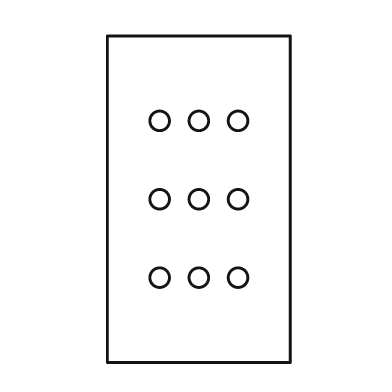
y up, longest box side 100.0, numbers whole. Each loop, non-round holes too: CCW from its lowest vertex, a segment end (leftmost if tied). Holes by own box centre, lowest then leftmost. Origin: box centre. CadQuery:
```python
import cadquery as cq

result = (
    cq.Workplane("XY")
    .moveTo(-28.0, -50.0)
    .lineTo(28.0, -50.0)
    .lineTo(28.0, 50.0)
    .lineTo(-28.0, 50.0)
    .close()
    .moveTo(-12.0, -24.0)
    .circle(3.0)
    .moveTo(0.0, -24.0)
    .circle(3.0)
    .moveTo(12.0, -24.0)
    .circle(3.0)
    .moveTo(-12.0, 0.0)
    .circle(3.0)
    .moveTo(0.0, 0.0)
    .circle(3.0)
    .moveTo(12.0, 0.0)
    .circle(3.0)
    .moveTo(-12.0, 24.0)
    .circle(3.0)
    .moveTo(0.0, 24.0)
    .circle(3.0)
    .moveTo(12.0, 24.0)
    .circle(3.0)
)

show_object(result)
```